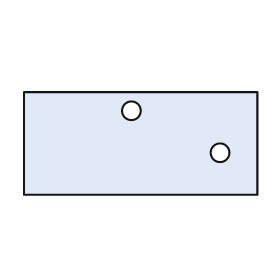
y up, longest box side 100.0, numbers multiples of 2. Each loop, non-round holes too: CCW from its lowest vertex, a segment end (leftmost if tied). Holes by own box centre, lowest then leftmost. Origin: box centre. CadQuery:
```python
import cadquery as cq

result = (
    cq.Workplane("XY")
    .moveTo(-50.0, -22.0)
    .lineTo(50.0, -22.0)
    .lineTo(50.0, 22.0)
    .lineTo(-50.0, 22.0)
    .close()
    .moveTo(34.0, -4.0)
    .circle(4.0)
    .moveTo(-4.0, 14.0)
    .circle(4.0)
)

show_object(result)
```